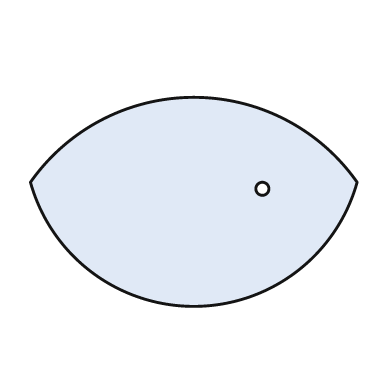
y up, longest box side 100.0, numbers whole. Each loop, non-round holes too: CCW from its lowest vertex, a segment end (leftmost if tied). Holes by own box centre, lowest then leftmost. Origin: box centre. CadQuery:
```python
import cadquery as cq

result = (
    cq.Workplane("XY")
    .moveTo(-50.0, 6.0)
    .threePointArc((0.0, -32.0), (50.0, 6.0))
    .threePointArc((0.0, 32.0), (-50.0, 6.0))
    .close()
    .moveTo(21.0, 4.0)
    .circle(2.0)
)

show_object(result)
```